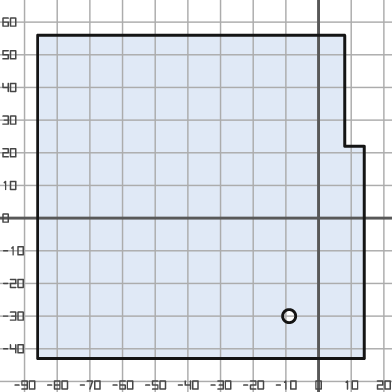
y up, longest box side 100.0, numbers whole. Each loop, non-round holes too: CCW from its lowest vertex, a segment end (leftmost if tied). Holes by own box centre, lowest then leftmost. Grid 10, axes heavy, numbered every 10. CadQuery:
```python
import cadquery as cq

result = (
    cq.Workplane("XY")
    .moveTo(-86.0, -43.0)
    .lineTo(14.0, -43.0)
    .lineTo(14.0, 22.0)
    .lineTo(8.0, 22.0)
    .lineTo(8.0, 56.0)
    .lineTo(-86.0, 56.0)
    .close()
    .moveTo(-9.0, -30.0)
    .circle(2.0)
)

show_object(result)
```